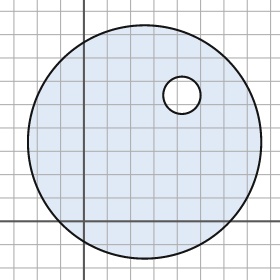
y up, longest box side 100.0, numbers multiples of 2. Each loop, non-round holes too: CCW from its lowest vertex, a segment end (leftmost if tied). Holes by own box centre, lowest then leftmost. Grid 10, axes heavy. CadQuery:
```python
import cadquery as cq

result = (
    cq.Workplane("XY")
    .moveTo(26.0, 34.0)
    .circle(50.0)
    .moveTo(42.0, 54.0)
    .circle(8.0)
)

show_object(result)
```